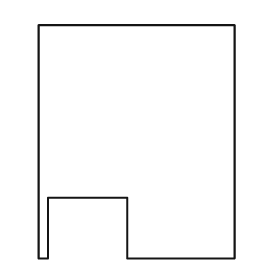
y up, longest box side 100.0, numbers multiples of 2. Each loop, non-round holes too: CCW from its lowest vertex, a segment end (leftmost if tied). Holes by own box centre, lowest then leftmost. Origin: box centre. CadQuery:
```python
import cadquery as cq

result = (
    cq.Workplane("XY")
    .moveTo(-42.0, -50.0)
    .lineTo(-38.0, -50.0)
    .lineTo(-38.0, -24.0)
    .lineTo(-4.0, -24.0)
    .lineTo(-4.0, -50.0)
    .lineTo(42.0, -50.0)
    .lineTo(42.0, 50.0)
    .lineTo(-42.0, 50.0)
    .close()
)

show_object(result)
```